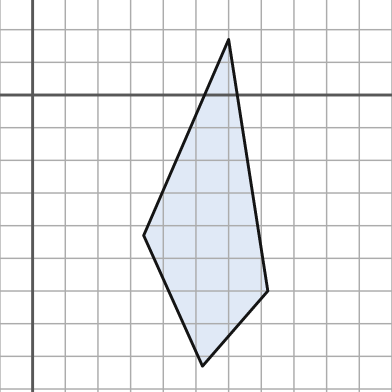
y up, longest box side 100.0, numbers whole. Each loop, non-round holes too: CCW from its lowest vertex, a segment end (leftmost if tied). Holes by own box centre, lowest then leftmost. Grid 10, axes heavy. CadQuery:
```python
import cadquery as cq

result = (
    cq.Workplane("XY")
    .moveTo(52.0, -83.0)
    .lineTo(72.0, -60.0)
    .lineTo(60.0, 17.0)
    .lineTo(34.0, -43.0)
    .close()
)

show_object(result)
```